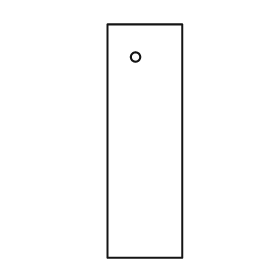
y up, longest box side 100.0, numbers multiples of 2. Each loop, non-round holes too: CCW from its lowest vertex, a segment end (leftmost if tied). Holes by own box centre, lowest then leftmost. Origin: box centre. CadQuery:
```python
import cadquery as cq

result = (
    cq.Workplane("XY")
    .moveTo(-16.0, -50.0)
    .lineTo(16.0, -50.0)
    .lineTo(16.0, 50.0)
    .lineTo(-16.0, 50.0)
    .close()
    .moveTo(-4.0, 36.0)
    .circle(2.0)
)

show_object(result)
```